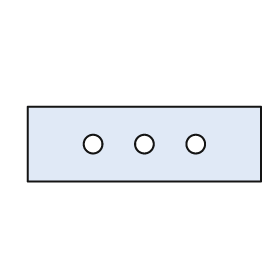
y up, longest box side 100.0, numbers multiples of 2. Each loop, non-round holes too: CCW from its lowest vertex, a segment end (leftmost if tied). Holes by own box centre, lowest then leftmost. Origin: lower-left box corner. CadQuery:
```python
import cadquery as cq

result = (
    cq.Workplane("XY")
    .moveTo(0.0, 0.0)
    .lineTo(100.0, 0.0)
    .lineTo(100.0, 32.0)
    .lineTo(0.0, 32.0)
    .close()
    .moveTo(28.0, 16.0)
    .circle(4.0)
    .moveTo(50.0, 16.0)
    .circle(4.0)
    .moveTo(72.0, 16.0)
    .circle(4.0)
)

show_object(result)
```